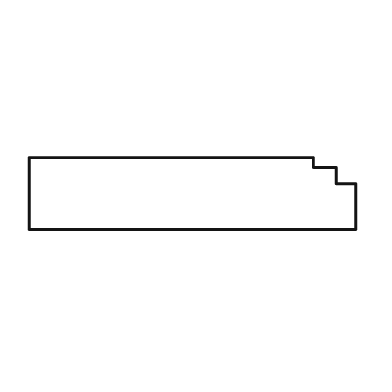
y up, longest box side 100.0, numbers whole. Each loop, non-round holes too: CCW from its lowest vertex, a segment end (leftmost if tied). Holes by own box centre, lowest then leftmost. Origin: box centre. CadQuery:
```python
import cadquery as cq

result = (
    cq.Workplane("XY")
    .moveTo(-50.0, -11.0)
    .lineTo(50.0, -11.0)
    .lineTo(50.0, 3.0)
    .lineTo(44.0, 3.0)
    .lineTo(44.0, 8.0)
    .lineTo(37.0, 8.0)
    .lineTo(37.0, 11.0)
    .lineTo(-50.0, 11.0)
    .close()
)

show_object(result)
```